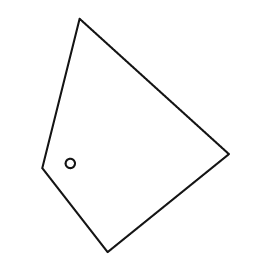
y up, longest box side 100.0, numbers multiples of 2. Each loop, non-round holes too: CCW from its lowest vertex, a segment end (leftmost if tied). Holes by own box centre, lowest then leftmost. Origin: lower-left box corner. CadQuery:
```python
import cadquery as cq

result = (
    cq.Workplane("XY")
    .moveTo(28.0, 0.0)
    .lineTo(80.0, 42.0)
    .lineTo(16.0, 100.0)
    .lineTo(0.0, 36.0)
    .close()
    .moveTo(12.0, 38.0)
    .circle(2.0)
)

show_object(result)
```